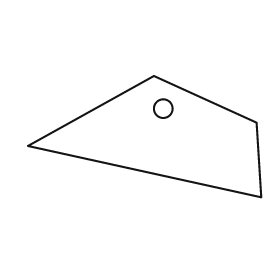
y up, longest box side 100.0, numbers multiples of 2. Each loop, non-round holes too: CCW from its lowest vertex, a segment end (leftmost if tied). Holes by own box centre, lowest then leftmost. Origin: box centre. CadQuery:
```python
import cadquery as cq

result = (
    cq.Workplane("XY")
    .moveTo(50.0, -26.0)
    .lineTo(48.0, 6.0)
    .lineTo(4.0, 26.0)
    .lineTo(-50.0, -4.0)
    .close()
    .moveTo(8.0, 12.0)
    .circle(4.0)
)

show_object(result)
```